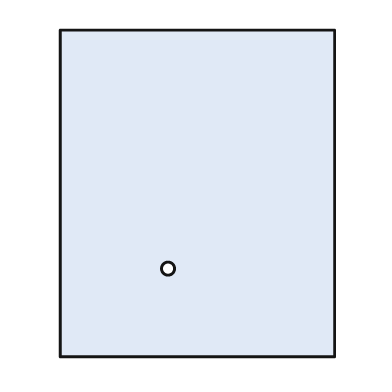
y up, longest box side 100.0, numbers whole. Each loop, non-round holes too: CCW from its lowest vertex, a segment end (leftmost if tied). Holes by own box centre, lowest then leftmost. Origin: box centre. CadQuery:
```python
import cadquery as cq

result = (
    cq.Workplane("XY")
    .moveTo(-42.0, -50.0)
    .lineTo(42.0, -50.0)
    .lineTo(42.0, 50.0)
    .lineTo(-42.0, 50.0)
    .close()
    .moveTo(-9.0, -23.0)
    .circle(2.0)
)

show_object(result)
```